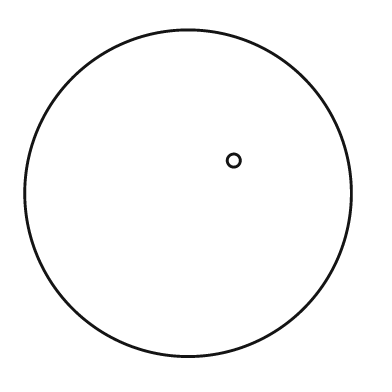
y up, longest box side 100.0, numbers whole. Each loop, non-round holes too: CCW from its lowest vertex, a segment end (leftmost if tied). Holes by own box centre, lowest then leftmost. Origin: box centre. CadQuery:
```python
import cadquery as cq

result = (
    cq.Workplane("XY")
    .moveTo(0.0, 0.0)
    .circle(50.0)
    .moveTo(14.0, 10.0)
    .circle(2.0)
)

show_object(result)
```